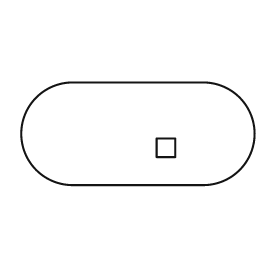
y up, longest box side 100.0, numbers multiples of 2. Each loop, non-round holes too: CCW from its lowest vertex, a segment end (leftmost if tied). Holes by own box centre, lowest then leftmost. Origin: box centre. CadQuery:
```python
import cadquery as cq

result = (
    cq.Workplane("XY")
    .moveTo(-28.0, -22.0)
    .lineTo(28.0, -22.0)
    .threePointArc((50.0, 0.0), (28.0, 22.0))
    .lineTo(-28.0, 22.0)
    .threePointArc((-50.0, 0.0), (-28.0, -22.0))
    .close()
    .moveTo(8.0, -10.0)
    .lineTo(16.0, -10.0)
    .lineTo(16.0, -2.0)
    .lineTo(8.0, -2.0)
    .close()
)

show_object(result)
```